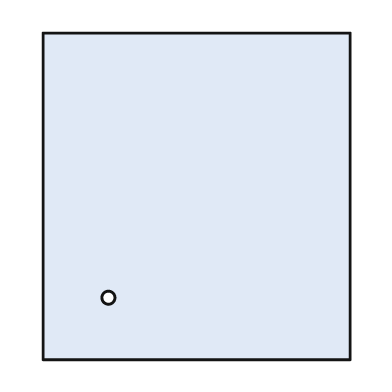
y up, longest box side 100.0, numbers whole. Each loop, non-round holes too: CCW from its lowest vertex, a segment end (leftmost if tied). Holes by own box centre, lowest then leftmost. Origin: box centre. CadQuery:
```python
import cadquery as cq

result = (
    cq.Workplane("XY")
    .moveTo(-47.0, -50.0)
    .lineTo(47.0, -50.0)
    .lineTo(47.0, 50.0)
    .lineTo(-47.0, 50.0)
    .close()
    .moveTo(-27.0, -31.0)
    .circle(2.0)
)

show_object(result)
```